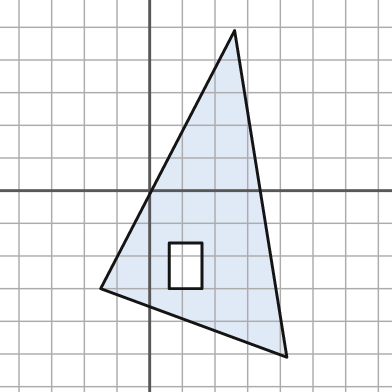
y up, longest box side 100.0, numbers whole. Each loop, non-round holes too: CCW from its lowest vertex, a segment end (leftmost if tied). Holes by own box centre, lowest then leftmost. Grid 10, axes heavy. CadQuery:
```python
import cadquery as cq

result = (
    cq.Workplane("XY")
    .moveTo(42.0, -51.0)
    .lineTo(26.0, 49.0)
    .lineTo(-15.0, -30.0)
    .close()
    .moveTo(6.0, -30.0)
    .lineTo(16.0, -30.0)
    .lineTo(16.0, -16.0)
    .lineTo(6.0, -16.0)
    .close()
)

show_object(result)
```